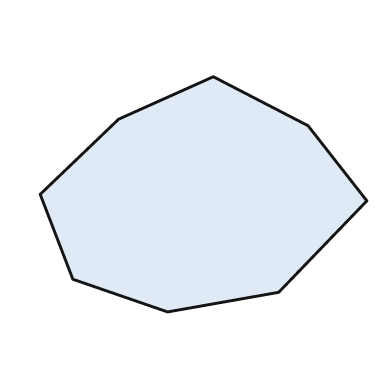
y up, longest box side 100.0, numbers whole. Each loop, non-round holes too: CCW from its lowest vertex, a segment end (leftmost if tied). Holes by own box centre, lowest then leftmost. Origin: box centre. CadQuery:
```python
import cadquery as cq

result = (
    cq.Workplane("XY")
    .moveTo(-11.0, -36.0)
    .lineTo(23.0, -30.0)
    .lineTo(50.0, -2.0)
    .lineTo(32.0, 21.0)
    .lineTo(3.0, 36.0)
    .lineTo(-26.0, 23.0)
    .lineTo(-50.0, 0.0)
    .lineTo(-40.0, -26.0)
    .close()
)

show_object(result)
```